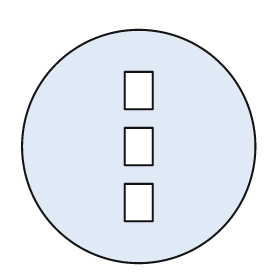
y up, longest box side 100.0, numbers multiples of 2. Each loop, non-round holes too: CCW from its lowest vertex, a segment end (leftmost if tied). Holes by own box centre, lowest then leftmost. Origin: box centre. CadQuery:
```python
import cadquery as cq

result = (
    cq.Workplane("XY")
    .moveTo(0.0, 0.0)
    .circle(50.0)
    .moveTo(-6.0, -32.0)
    .lineTo(6.0, -32.0)
    .lineTo(6.0, -16.0)
    .lineTo(-6.0, -16.0)
    .close()
    .moveTo(-6.0, -8.0)
    .lineTo(6.0, -8.0)
    .lineTo(6.0, 8.0)
    .lineTo(-6.0, 8.0)
    .close()
    .moveTo(-6.0, 16.0)
    .lineTo(6.0, 16.0)
    .lineTo(6.0, 32.0)
    .lineTo(-6.0, 32.0)
    .close()
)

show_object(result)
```